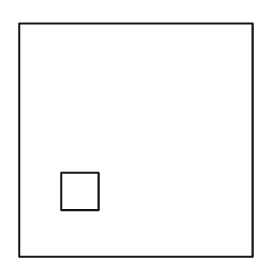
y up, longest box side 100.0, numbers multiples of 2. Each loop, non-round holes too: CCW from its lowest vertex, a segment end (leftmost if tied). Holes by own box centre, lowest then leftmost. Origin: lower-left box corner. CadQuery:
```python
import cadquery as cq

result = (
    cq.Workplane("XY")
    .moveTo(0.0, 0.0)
    .lineTo(100.0, 0.0)
    .lineTo(100.0, 100.0)
    .lineTo(0.0, 100.0)
    .close()
    .moveTo(18.0, 20.0)
    .lineTo(34.0, 20.0)
    .lineTo(34.0, 36.0)
    .lineTo(18.0, 36.0)
    .close()
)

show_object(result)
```